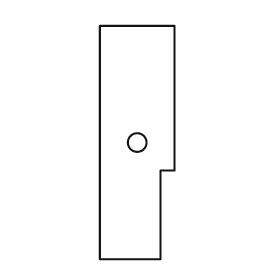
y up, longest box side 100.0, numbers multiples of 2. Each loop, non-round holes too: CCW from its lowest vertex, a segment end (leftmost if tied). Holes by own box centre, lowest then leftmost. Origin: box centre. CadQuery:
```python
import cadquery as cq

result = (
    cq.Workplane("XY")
    .moveTo(-16.0, -50.0)
    .lineTo(10.0, -50.0)
    .lineTo(10.0, -12.0)
    .lineTo(16.0, -12.0)
    .lineTo(16.0, 50.0)
    .lineTo(-16.0, 50.0)
    .close()
    .moveTo(0.0, 0.0)
    .circle(4.0)
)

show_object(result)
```